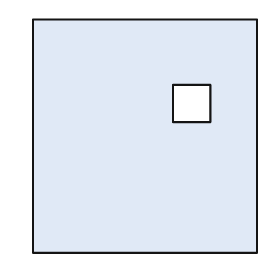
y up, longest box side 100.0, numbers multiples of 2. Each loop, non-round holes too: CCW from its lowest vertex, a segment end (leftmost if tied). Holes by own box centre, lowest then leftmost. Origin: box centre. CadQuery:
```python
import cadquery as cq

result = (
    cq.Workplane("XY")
    .moveTo(-48.0, -50.0)
    .lineTo(48.0, -50.0)
    .lineTo(48.0, 50.0)
    .lineTo(-48.0, 50.0)
    .close()
    .moveTo(12.0, 6.0)
    .lineTo(28.0, 6.0)
    .lineTo(28.0, 22.0)
    .lineTo(12.0, 22.0)
    .close()
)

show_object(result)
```